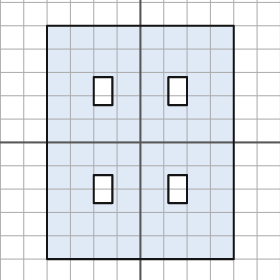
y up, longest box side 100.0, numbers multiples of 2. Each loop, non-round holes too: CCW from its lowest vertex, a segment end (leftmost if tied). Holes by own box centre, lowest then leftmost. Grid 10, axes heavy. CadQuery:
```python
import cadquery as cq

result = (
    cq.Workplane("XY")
    .moveTo(-40.0, -50.0)
    .lineTo(40.0, -50.0)
    .lineTo(40.0, 50.0)
    .lineTo(-40.0, 50.0)
    .close()
    .moveTo(-20.0, -26.0)
    .lineTo(-12.0, -26.0)
    .lineTo(-12.0, -14.0)
    .lineTo(-20.0, -14.0)
    .close()
    .moveTo(12.0, -26.0)
    .lineTo(20.0, -26.0)
    .lineTo(20.0, -14.0)
    .lineTo(12.0, -14.0)
    .close()
    .moveTo(-20.0, 16.0)
    .lineTo(-12.0, 16.0)
    .lineTo(-12.0, 28.0)
    .lineTo(-20.0, 28.0)
    .close()
    .moveTo(12.0, 16.0)
    .lineTo(20.0, 16.0)
    .lineTo(20.0, 28.0)
    .lineTo(12.0, 28.0)
    .close()
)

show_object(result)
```